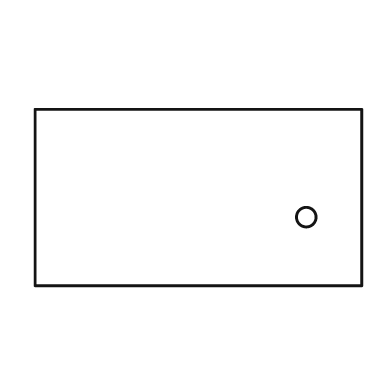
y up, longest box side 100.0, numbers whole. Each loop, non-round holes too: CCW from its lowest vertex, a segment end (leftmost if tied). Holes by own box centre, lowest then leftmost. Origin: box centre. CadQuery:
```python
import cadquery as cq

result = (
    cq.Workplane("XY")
    .moveTo(-50.0, -27.0)
    .lineTo(50.0, -27.0)
    .lineTo(50.0, 27.0)
    .lineTo(-50.0, 27.0)
    .close()
    .moveTo(33.0, -6.0)
    .circle(3.0)
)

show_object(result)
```